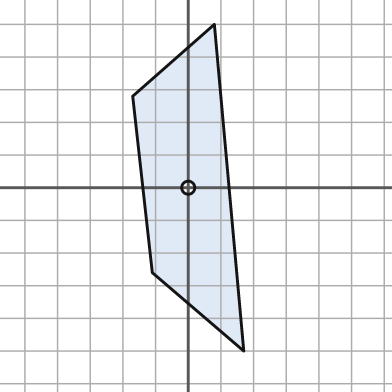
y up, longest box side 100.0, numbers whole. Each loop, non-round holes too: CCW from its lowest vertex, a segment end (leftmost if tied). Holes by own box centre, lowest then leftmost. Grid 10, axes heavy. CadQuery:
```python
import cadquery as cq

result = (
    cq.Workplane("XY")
    .moveTo(17.0, -50.0)
    .lineTo(8.0, 50.0)
    .lineTo(-17.0, 28.0)
    .lineTo(-11.0, -26.0)
    .close()
    .moveTo(0.0, 0.0)
    .circle(2.0)
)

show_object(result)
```